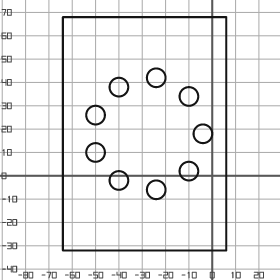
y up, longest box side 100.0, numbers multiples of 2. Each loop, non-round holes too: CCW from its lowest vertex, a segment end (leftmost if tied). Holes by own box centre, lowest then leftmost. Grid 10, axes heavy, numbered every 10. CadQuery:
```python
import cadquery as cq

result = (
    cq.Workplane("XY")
    .moveTo(-64.0, -32.0)
    .lineTo(6.0, -32.0)
    .lineTo(6.0, 68.0)
    .lineTo(-64.0, 68.0)
    .close()
    .moveTo(-24.0, -6.0)
    .circle(4.0)
    .moveTo(-40.0, -2.0)
    .circle(4.0)
    .moveTo(-10.0, 2.0)
    .circle(4.0)
    .moveTo(-50.0, 10.0)
    .circle(4.0)
    .moveTo(-4.0, 18.0)
    .circle(4.0)
    .moveTo(-50.0, 26.0)
    .circle(4.0)
    .moveTo(-10.0, 34.0)
    .circle(4.0)
    .moveTo(-40.0, 38.0)
    .circle(4.0)
    .moveTo(-24.0, 42.0)
    .circle(4.0)
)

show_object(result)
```